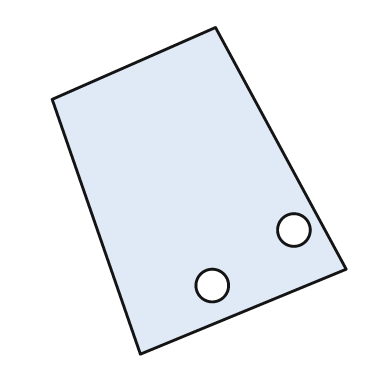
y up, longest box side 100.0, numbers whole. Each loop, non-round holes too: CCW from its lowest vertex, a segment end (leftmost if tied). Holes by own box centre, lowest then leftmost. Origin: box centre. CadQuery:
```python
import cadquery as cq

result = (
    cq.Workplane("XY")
    .moveTo(-18.0, -50.0)
    .lineTo(45.0, -24.0)
    .lineTo(5.0, 50.0)
    .lineTo(-45.0, 28.0)
    .close()
    .moveTo(4.0, -29.0)
    .circle(5.0)
    .moveTo(29.0, -12.0)
    .circle(5.0)
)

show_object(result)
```